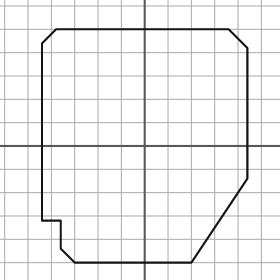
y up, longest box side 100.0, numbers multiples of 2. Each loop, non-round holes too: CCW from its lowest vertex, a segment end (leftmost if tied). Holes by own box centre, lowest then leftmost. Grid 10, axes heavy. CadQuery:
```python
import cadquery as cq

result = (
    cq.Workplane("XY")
    .moveTo(-30.0, -50.0)
    .lineTo(20.0, -50.0)
    .lineTo(44.0, -14.0)
    .lineTo(44.0, 42.0)
    .lineTo(36.0, 50.0)
    .lineTo(-38.0, 50.0)
    .lineTo(-44.0, 44.0)
    .lineTo(-44.0, -32.0)
    .lineTo(-36.0, -32.0)
    .lineTo(-36.0, -44.0)
    .close()
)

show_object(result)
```